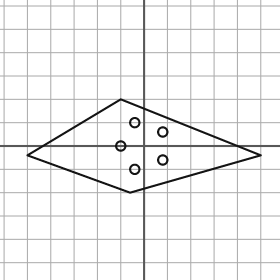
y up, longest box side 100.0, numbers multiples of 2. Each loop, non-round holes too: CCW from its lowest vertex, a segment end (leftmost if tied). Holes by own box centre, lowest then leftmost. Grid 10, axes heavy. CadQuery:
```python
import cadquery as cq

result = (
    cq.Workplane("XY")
    .moveTo(-6.0, -20.0)
    .lineTo(50.0, -4.0)
    .lineTo(-10.0, 20.0)
    .lineTo(-50.0, -4.0)
    .close()
    .moveTo(-4.0, -10.0)
    .circle(2.0)
    .moveTo(8.0, -6.0)
    .circle(2.0)
    .moveTo(-10.0, 0.0)
    .circle(2.0)
    .moveTo(8.0, 6.0)
    .circle(2.0)
    .moveTo(-4.0, 10.0)
    .circle(2.0)
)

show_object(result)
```